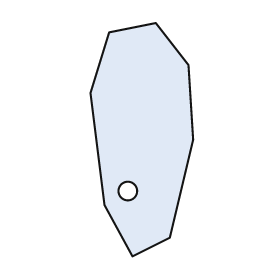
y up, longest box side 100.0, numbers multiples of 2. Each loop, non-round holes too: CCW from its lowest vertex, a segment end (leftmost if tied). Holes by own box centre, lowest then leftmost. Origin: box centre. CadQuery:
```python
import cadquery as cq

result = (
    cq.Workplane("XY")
    .moveTo(-4.0, -50.0)
    .lineTo(12.0, -42.0)
    .lineTo(22.0, 0.0)
    .lineTo(20.0, 32.0)
    .lineTo(6.0, 50.0)
    .lineTo(-14.0, 46.0)
    .lineTo(-22.0, 20.0)
    .lineTo(-16.0, -28.0)
    .close()
    .moveTo(-6.0, -22.0)
    .circle(4.0)
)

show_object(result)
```